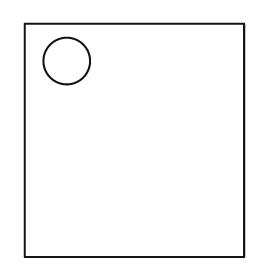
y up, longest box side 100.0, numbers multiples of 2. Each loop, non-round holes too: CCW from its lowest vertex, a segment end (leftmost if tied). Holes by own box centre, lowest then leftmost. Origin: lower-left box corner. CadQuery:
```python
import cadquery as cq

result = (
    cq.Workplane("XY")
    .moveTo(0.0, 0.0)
    .lineTo(94.0, 0.0)
    .lineTo(94.0, 100.0)
    .lineTo(0.0, 100.0)
    .close()
    .moveTo(18.0, 84.0)
    .circle(10.0)
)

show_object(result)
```